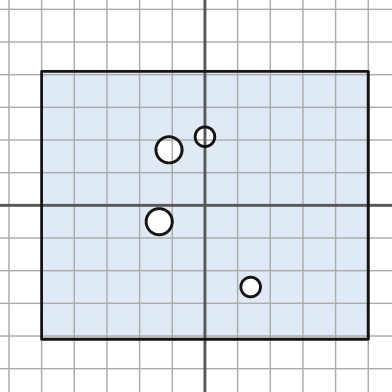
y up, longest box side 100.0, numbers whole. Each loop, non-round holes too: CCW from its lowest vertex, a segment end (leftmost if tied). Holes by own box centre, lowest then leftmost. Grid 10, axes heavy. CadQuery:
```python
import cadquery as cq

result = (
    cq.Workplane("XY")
    .moveTo(-50.0, -41.0)
    .lineTo(50.0, -41.0)
    .lineTo(50.0, 41.0)
    .lineTo(-50.0, 41.0)
    .close()
    .moveTo(14.0, -25.0)
    .circle(3.0)
    .moveTo(-14.0, -5.0)
    .circle(4.0)
    .moveTo(-11.0, 17.0)
    .circle(4.0)
    .moveTo(0.0, 21.0)
    .circle(3.0)
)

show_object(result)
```